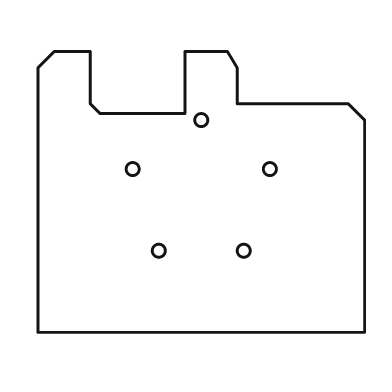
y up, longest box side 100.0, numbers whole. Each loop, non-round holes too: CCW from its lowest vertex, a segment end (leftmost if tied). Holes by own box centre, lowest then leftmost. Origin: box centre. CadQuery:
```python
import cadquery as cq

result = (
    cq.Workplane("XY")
    .moveTo(-50.0, -43.0)
    .lineTo(50.0, -43.0)
    .lineTo(50.0, 22.0)
    .lineTo(45.0, 27.0)
    .lineTo(11.0, 27.0)
    .lineTo(11.0, 38.0)
    .lineTo(8.0, 43.0)
    .lineTo(-5.0, 43.0)
    .lineTo(-5.0, 24.0)
    .lineTo(-31.0, 24.0)
    .lineTo(-34.0, 27.0)
    .lineTo(-34.0, 43.0)
    .lineTo(-45.0, 43.0)
    .lineTo(-50.0, 38.0)
    .close()
    .moveTo(-13.0, -18.0)
    .circle(2.0)
    .moveTo(13.0, -18.0)
    .circle(2.0)
    .moveTo(-21.0, 7.0)
    .circle(2.0)
    .moveTo(21.0, 7.0)
    .circle(2.0)
    .moveTo(0.0, 22.0)
    .circle(2.0)
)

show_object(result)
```